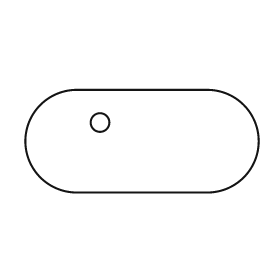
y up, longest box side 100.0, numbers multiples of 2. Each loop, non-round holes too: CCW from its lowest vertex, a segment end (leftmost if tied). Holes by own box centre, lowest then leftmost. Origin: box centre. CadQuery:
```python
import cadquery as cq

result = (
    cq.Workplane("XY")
    .moveTo(-28.0, -22.0)
    .lineTo(28.0, -22.0)
    .threePointArc((50.0, 0.0), (28.0, 22.0))
    .lineTo(-28.0, 22.0)
    .threePointArc((-50.0, 0.0), (-28.0, -22.0))
    .close()
    .moveTo(-18.0, 8.0)
    .circle(4.0)
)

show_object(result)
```